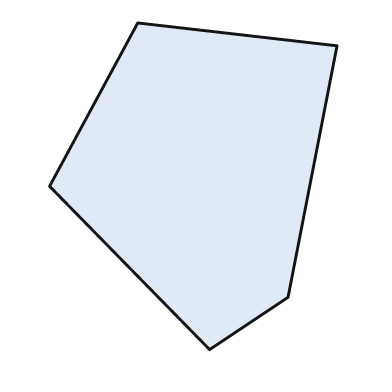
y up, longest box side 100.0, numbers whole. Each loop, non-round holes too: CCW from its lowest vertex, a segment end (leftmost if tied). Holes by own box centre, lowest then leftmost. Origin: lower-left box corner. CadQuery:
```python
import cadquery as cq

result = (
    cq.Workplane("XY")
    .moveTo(49.0, 0.0)
    .lineTo(73.0, 16.0)
    .lineTo(88.0, 93.0)
    .lineTo(27.0, 100.0)
    .lineTo(0.0, 50.0)
    .close()
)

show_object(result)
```